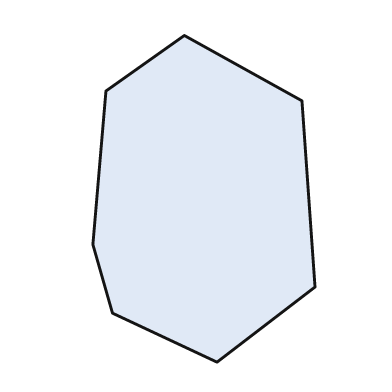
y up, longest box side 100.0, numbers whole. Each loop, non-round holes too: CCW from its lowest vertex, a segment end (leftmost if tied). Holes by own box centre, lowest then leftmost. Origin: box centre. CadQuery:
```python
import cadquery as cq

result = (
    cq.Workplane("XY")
    .moveTo(4.0, -50.0)
    .lineTo(34.0, -27.0)
    .lineTo(30.0, 30.0)
    .lineTo(-6.0, 50.0)
    .lineTo(-30.0, 33.0)
    .lineTo(-34.0, -14.0)
    .lineTo(-28.0, -35.0)
    .close()
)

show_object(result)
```